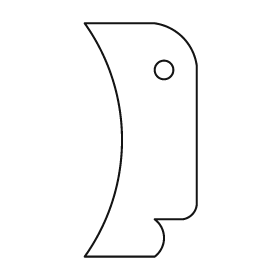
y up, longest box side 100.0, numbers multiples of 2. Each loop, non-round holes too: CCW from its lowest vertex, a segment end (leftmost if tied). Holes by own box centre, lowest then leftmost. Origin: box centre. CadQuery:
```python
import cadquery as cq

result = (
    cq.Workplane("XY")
    .moveTo(-24.0, -50.0)
    .lineTo(6.0, -50.0)
    .threePointArc((10.0, -42.0), (6.0, -34.0))
    .lineTo(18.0, -34.0)
    .threePointArc((22.0, -32.0), (24.0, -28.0))
    .lineTo(24.0, 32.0)
    .threePointArc((18.0, 44.0), (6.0, 50.0))
    .lineTo(-24.0, 50.0)
    .threePointArc((-8.0, 0.0), (-24.0, -50.0))
    .close()
    .moveTo(10.0, 30.0)
    .circle(4.0)
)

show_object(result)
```